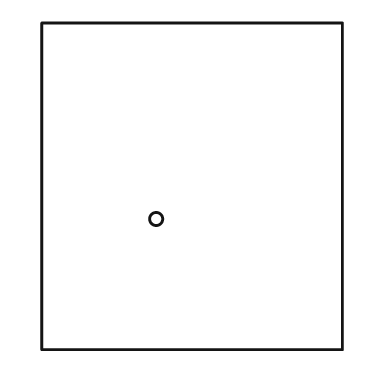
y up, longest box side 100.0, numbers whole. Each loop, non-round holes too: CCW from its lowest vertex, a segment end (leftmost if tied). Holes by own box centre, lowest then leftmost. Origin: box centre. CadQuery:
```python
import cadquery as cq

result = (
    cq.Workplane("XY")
    .moveTo(-46.0, -50.0)
    .lineTo(46.0, -50.0)
    .lineTo(46.0, 50.0)
    .lineTo(-46.0, 50.0)
    .close()
    .moveTo(-11.0, -10.0)
    .circle(2.0)
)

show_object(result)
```